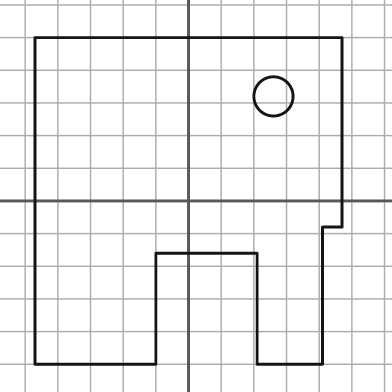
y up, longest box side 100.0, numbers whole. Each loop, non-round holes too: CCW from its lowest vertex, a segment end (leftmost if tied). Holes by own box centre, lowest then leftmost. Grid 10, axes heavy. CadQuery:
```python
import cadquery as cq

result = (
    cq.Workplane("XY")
    .moveTo(-47.0, -50.0)
    .lineTo(-10.0, -50.0)
    .lineTo(-10.0, -16.0)
    .lineTo(21.0, -16.0)
    .lineTo(21.0, -50.0)
    .lineTo(41.0, -50.0)
    .lineTo(41.0, -8.0)
    .lineTo(47.0, -8.0)
    .lineTo(47.0, 50.0)
    .lineTo(-47.0, 50.0)
    .close()
    .moveTo(26.0, 32.0)
    .circle(6.0)
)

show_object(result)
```